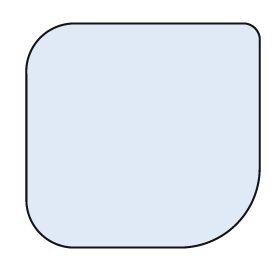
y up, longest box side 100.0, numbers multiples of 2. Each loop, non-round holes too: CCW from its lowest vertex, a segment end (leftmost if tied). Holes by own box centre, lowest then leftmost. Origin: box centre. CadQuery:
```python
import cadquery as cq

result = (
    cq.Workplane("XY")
    .moveTo(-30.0, -48.0)
    .lineTo(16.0, -48.0)
    .threePointArc((40.0, -38.0), (50.0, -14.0))
    .lineTo(50.0, 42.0)
    .threePointArc((48.0, 46.0), (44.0, 48.0))
    .lineTo(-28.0, 48.0)
    .threePointArc((-44.0, 42.0), (-50.0, 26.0))
    .lineTo(-50.0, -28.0)
    .threePointArc((-44.0, -42.0), (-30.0, -48.0))
    .close()
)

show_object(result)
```